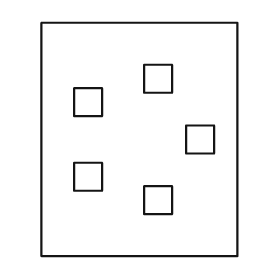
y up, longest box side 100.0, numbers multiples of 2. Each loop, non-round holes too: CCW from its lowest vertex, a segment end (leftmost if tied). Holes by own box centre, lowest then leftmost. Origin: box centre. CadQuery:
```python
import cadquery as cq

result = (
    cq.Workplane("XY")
    .moveTo(-42.0, -50.0)
    .lineTo(42.0, -50.0)
    .lineTo(42.0, 50.0)
    .lineTo(-42.0, 50.0)
    .close()
    .moveTo(2.0, -32.0)
    .lineTo(14.0, -32.0)
    .lineTo(14.0, -20.0)
    .lineTo(2.0, -20.0)
    .close()
    .moveTo(-28.0, -22.0)
    .lineTo(-16.0, -22.0)
    .lineTo(-16.0, -10.0)
    .lineTo(-28.0, -10.0)
    .close()
    .moveTo(20.0, -6.0)
    .lineTo(32.0, -6.0)
    .lineTo(32.0, 6.0)
    .lineTo(20.0, 6.0)
    .close()
    .moveTo(-28.0, 10.0)
    .lineTo(-16.0, 10.0)
    .lineTo(-16.0, 22.0)
    .lineTo(-28.0, 22.0)
    .close()
    .moveTo(2.0, 20.0)
    .lineTo(14.0, 20.0)
    .lineTo(14.0, 32.0)
    .lineTo(2.0, 32.0)
    .close()
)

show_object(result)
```